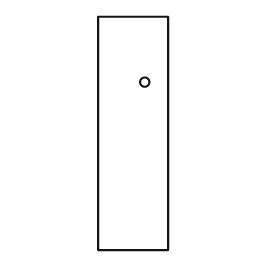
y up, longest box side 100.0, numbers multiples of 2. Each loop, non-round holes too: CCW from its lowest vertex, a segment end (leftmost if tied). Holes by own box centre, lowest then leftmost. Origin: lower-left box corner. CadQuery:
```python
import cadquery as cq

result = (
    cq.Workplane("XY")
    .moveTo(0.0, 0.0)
    .lineTo(30.0, 0.0)
    .lineTo(30.0, 100.0)
    .lineTo(0.0, 100.0)
    .close()
    .moveTo(20.0, 72.0)
    .circle(2.0)
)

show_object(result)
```